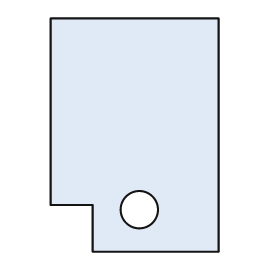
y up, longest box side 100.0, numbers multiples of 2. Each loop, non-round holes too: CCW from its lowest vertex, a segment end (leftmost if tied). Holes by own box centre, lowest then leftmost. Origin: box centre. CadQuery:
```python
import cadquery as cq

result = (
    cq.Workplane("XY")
    .moveTo(-18.0, -50.0)
    .lineTo(36.0, -50.0)
    .lineTo(36.0, 50.0)
    .lineTo(-36.0, 50.0)
    .lineTo(-36.0, -30.0)
    .lineTo(-18.0, -30.0)
    .close()
    .moveTo(2.0, -32.0)
    .circle(8.0)
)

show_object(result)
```